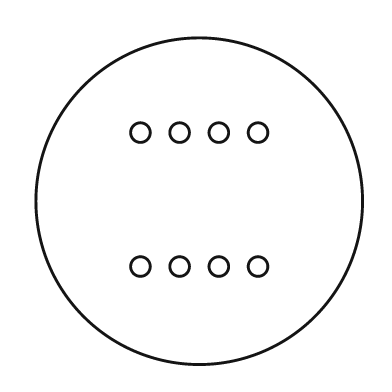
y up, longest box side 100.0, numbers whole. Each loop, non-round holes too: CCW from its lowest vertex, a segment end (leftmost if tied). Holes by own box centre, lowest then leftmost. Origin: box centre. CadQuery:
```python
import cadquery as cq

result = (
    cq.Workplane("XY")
    .moveTo(0.0, 0.0)
    .circle(50.0)
    .moveTo(-18.0, -20.0)
    .circle(3.0)
    .moveTo(-6.0, -20.0)
    .circle(3.0)
    .moveTo(6.0, -20.0)
    .circle(3.0)
    .moveTo(18.0, -20.0)
    .circle(3.0)
    .moveTo(-18.0, 21.0)
    .circle(3.0)
    .moveTo(-6.0, 21.0)
    .circle(3.0)
    .moveTo(6.0, 21.0)
    .circle(3.0)
    .moveTo(18.0, 21.0)
    .circle(3.0)
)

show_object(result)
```